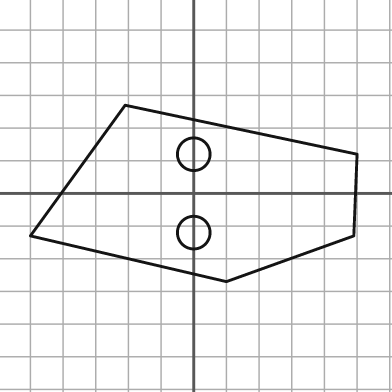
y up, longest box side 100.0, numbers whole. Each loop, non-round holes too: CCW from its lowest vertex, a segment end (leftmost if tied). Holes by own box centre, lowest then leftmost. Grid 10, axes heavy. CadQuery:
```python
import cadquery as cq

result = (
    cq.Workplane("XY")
    .moveTo(10.0, -27.0)
    .lineTo(49.0, -13.0)
    .lineTo(50.0, 12.0)
    .lineTo(-21.0, 27.0)
    .lineTo(-50.0, -13.0)
    .close()
    .moveTo(0.0, -12.0)
    .circle(5.0)
    .moveTo(0.0, 12.0)
    .circle(5.0)
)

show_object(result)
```